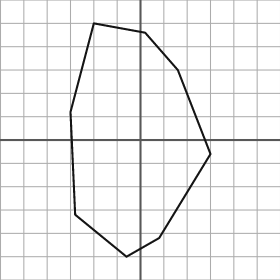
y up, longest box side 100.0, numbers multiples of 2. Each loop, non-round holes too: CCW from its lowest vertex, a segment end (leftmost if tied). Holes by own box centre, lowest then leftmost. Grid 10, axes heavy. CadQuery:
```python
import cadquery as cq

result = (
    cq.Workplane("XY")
    .moveTo(-6.0, -50.0)
    .lineTo(8.0, -42.0)
    .lineTo(30.0, -6.0)
    .lineTo(16.0, 30.0)
    .lineTo(2.0, 46.0)
    .lineTo(-20.0, 50.0)
    .lineTo(-30.0, 12.0)
    .lineTo(-28.0, -32.0)
    .close()
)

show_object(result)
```